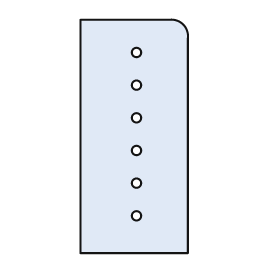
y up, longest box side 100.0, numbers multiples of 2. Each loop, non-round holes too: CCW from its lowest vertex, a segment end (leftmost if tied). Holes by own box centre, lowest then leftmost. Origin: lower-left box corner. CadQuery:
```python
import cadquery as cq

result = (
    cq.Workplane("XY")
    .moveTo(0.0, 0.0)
    .lineTo(46.0, 0.0)
    .lineTo(46.0, 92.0)
    .threePointArc((44.0, 98.0), (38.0, 100.0))
    .lineTo(0.0, 100.0)
    .close()
    .moveTo(24.0, 16.0)
    .circle(2.0)
    .moveTo(24.0, 30.0)
    .circle(2.0)
    .moveTo(24.0, 44.0)
    .circle(2.0)
    .moveTo(24.0, 58.0)
    .circle(2.0)
    .moveTo(24.0, 72.0)
    .circle(2.0)
    .moveTo(24.0, 86.0)
    .circle(2.0)
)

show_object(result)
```